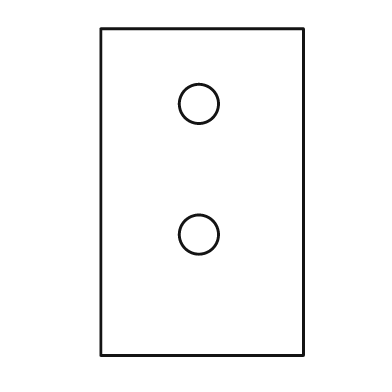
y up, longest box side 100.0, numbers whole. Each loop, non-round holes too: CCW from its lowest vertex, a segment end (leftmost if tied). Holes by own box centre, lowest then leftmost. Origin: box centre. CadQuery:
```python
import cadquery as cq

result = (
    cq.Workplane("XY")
    .moveTo(-31.0, -50.0)
    .lineTo(31.0, -50.0)
    .lineTo(31.0, 50.0)
    .lineTo(-31.0, 50.0)
    .close()
    .moveTo(-1.0, -13.0)
    .circle(6.0)
    .moveTo(-1.0, 27.0)
    .circle(6.0)
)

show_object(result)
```